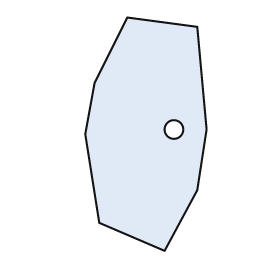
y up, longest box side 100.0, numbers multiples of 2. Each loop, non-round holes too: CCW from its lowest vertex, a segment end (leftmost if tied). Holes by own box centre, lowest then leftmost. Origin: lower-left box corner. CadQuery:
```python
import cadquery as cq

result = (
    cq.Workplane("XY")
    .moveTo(34.0, 0.0)
    .lineTo(48.0, 26.0)
    .lineTo(52.0, 52.0)
    .lineTo(48.0, 96.0)
    .lineTo(18.0, 100.0)
    .lineTo(4.0, 72.0)
    .lineTo(0.0, 50.0)
    .lineTo(6.0, 12.0)
    .close()
    .moveTo(38.0, 52.0)
    .circle(4.0)
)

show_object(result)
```